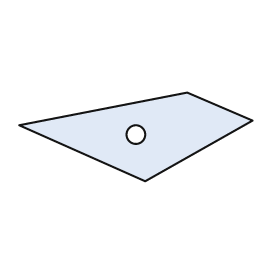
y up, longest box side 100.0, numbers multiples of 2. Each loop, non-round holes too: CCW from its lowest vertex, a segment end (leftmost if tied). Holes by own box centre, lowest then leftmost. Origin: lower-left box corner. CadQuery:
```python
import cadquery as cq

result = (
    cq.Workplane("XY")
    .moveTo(54.0, 0.0)
    .lineTo(100.0, 26.0)
    .lineTo(72.0, 38.0)
    .lineTo(0.0, 24.0)
    .close()
    .moveTo(50.0, 20.0)
    .circle(4.0)
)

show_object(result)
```